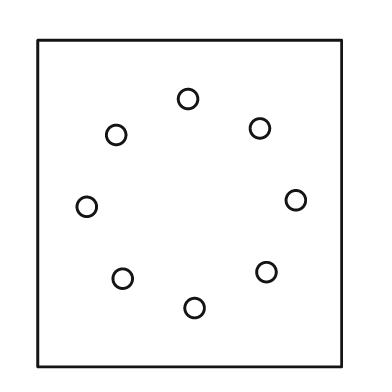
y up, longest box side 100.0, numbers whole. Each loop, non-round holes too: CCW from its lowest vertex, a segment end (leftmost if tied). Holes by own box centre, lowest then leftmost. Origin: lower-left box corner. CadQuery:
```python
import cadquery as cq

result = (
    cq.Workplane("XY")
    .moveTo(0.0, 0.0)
    .lineTo(93.0, 0.0)
    .lineTo(93.0, 100.0)
    .lineTo(0.0, 100.0)
    .close()
    .moveTo(48.0, 18.0)
    .circle(3.0)
    .moveTo(26.0, 27.0)
    .circle(3.0)
    .moveTo(70.0, 29.0)
    .circle(3.0)
    .moveTo(15.0, 49.0)
    .circle(3.0)
    .moveTo(79.0, 51.0)
    .circle(3.0)
    .moveTo(24.0, 71.0)
    .circle(3.0)
    .moveTo(68.0, 73.0)
    .circle(3.0)
    .moveTo(46.0, 82.0)
    .circle(3.0)
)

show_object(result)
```